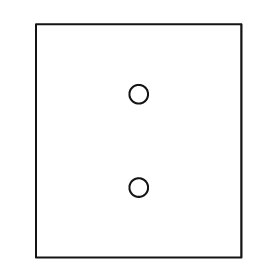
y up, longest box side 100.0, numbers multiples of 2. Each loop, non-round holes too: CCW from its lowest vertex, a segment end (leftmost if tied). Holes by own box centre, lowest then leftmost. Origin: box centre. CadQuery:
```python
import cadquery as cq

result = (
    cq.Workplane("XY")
    .moveTo(-44.0, -50.0)
    .lineTo(44.0, -50.0)
    .lineTo(44.0, 50.0)
    .lineTo(-44.0, 50.0)
    .close()
    .moveTo(0.0, -20.0)
    .circle(4.0)
    .moveTo(0.0, 20.0)
    .circle(4.0)
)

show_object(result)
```